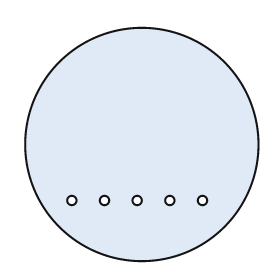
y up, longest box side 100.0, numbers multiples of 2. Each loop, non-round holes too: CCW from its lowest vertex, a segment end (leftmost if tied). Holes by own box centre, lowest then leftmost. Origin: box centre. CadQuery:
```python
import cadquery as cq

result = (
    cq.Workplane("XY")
    .moveTo(0.0, 0.0)
    .circle(50.0)
    .moveTo(-30.0, -24.0)
    .circle(2.0)
    .moveTo(-16.0, -24.0)
    .circle(2.0)
    .moveTo(-2.0, -24.0)
    .circle(2.0)
    .moveTo(12.0, -24.0)
    .circle(2.0)
    .moveTo(26.0, -24.0)
    .circle(2.0)
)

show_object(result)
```